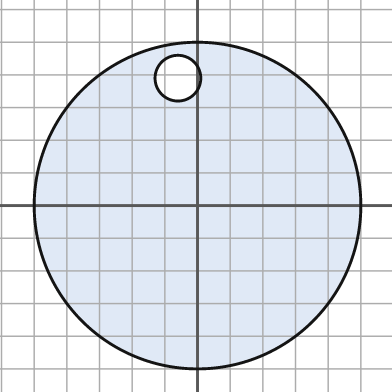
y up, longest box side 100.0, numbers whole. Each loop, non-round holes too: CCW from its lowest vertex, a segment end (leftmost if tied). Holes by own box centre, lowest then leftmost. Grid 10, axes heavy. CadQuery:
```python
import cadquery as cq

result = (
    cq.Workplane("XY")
    .moveTo(0.0, 0.0)
    .circle(50.0)
    .moveTo(-6.0, 39.0)
    .circle(7.0)
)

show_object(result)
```